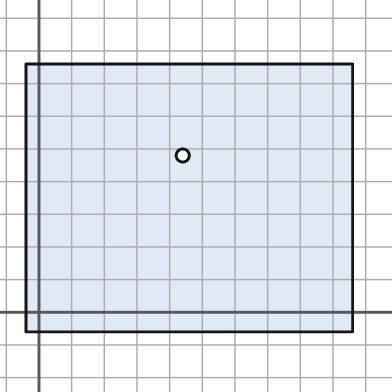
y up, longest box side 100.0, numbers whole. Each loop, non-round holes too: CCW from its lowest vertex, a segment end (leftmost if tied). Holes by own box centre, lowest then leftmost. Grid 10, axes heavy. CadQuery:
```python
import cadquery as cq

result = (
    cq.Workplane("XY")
    .moveTo(-4.0, -6.0)
    .lineTo(96.0, -6.0)
    .lineTo(96.0, 76.0)
    .lineTo(-4.0, 76.0)
    .close()
    .moveTo(44.0, 48.0)
    .circle(2.0)
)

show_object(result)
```